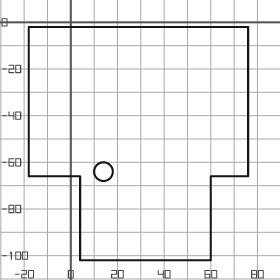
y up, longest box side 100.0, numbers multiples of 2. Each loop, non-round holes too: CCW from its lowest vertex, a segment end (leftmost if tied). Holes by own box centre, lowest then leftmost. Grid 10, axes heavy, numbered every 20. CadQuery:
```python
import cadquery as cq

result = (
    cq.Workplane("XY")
    .moveTo(4.0, -102.0)
    .lineTo(60.0, -102.0)
    .lineTo(60.0, -66.0)
    .lineTo(76.0, -66.0)
    .lineTo(76.0, -2.0)
    .lineTo(-18.0, -2.0)
    .lineTo(-18.0, -66.0)
    .lineTo(4.0, -66.0)
    .close()
    .moveTo(14.0, -64.0)
    .circle(4.0)
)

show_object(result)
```